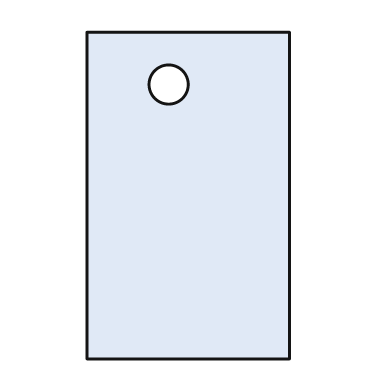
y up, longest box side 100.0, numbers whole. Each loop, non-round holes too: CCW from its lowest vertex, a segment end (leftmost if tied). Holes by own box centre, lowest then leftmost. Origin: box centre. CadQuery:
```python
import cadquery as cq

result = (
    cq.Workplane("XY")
    .moveTo(-31.0, -50.0)
    .lineTo(31.0, -50.0)
    .lineTo(31.0, 50.0)
    .lineTo(-31.0, 50.0)
    .close()
    .moveTo(-6.0, 34.0)
    .circle(6.0)
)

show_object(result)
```